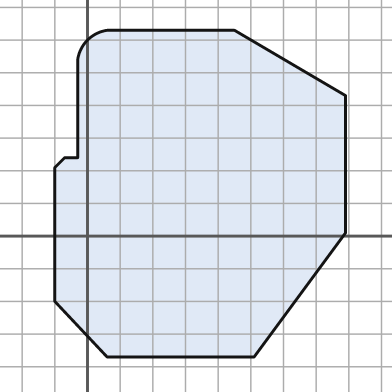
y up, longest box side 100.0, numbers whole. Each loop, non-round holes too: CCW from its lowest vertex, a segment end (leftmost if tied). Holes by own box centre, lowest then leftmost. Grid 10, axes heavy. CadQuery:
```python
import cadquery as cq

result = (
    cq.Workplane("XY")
    .moveTo(6.0, -37.0)
    .lineTo(51.0, -37.0)
    .lineTo(79.0, 1.0)
    .lineTo(79.0, 43.0)
    .lineTo(45.0, 63.0)
    .lineTo(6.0, 63.0)
    .threePointArc((0.0, 60.0), (-3.0, 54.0))
    .lineTo(-3.0, 24.0)
    .lineTo(-7.0, 24.0)
    .lineTo(-10.0, 21.0)
    .lineTo(-10.0, -20.0)
    .close()
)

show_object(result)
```